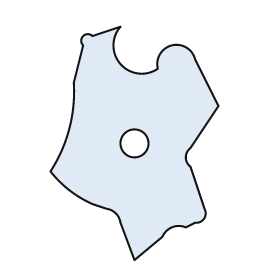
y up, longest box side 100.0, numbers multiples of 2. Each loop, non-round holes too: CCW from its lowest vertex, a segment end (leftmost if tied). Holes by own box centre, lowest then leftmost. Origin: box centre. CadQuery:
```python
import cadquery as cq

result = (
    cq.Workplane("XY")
    .moveTo(0.0, -50.0)
    .lineTo(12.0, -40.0)
    .threePointArc((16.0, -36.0), (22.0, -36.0))
    .lineTo(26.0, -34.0)
    .threePointArc((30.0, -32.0), (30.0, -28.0))
    .lineTo(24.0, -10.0)
    .threePointArc((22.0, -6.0), (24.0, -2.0))
    .lineTo(36.0, 16.0)
    .lineTo(26.0, 36.0)
    .threePointArc((16.0, 42.0), (10.0, 32.0))
    .threePointArc((-6.0, 34.0), (-6.0, 50.0))
    .lineTo(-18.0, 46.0)
    .threePointArc((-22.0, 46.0), (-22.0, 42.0))
    .lineTo(-26.0, 26.0)
    .threePointArc((-28.0, 6.0), (-36.0, -12.0))
    .threePointArc((-28.0, -20.0), (-18.0, -26.0))
    .lineTo(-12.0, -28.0)
    .threePointArc((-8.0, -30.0), (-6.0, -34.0))
    .close()
    .moveTo(0.0, 0.0)
    .circle(6.0)
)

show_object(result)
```